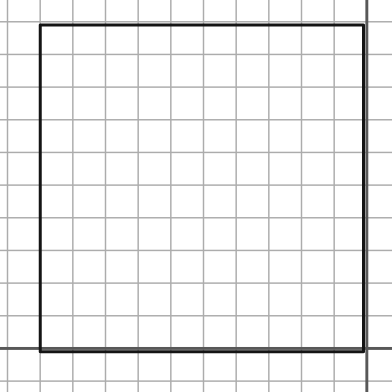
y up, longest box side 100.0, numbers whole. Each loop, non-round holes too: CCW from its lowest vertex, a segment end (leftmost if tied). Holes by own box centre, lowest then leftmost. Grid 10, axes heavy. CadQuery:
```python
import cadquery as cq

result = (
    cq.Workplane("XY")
    .moveTo(-100.0, -1.0)
    .lineTo(-1.0, -1.0)
    .lineTo(-1.0, 99.0)
    .lineTo(-100.0, 99.0)
    .close()
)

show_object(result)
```